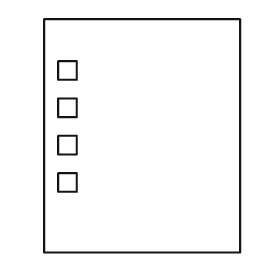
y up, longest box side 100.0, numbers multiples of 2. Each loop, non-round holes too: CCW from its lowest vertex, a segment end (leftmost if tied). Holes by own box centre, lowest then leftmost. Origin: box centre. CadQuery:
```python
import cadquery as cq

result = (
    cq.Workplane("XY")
    .moveTo(-42.0, -50.0)
    .lineTo(42.0, -50.0)
    .lineTo(42.0, 50.0)
    .lineTo(-42.0, 50.0)
    .close()
    .moveTo(-36.0, -24.0)
    .lineTo(-28.0, -24.0)
    .lineTo(-28.0, -16.0)
    .lineTo(-36.0, -16.0)
    .close()
    .moveTo(-36.0, -8.0)
    .lineTo(-28.0, -8.0)
    .lineTo(-28.0, 0.0)
    .lineTo(-36.0, 0.0)
    .close()
    .moveTo(-36.0, 8.0)
    .lineTo(-28.0, 8.0)
    .lineTo(-28.0, 16.0)
    .lineTo(-36.0, 16.0)
    .close()
    .moveTo(-36.0, 24.0)
    .lineTo(-28.0, 24.0)
    .lineTo(-28.0, 32.0)
    .lineTo(-36.0, 32.0)
    .close()
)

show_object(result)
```